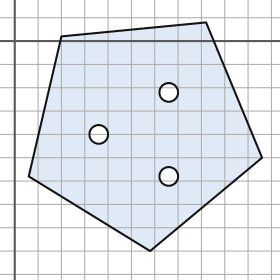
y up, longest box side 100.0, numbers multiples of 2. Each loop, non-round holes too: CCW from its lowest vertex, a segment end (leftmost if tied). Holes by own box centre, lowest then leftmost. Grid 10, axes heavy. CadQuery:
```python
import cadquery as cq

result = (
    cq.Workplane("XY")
    .moveTo(58.0, -90.0)
    .lineTo(106.0, -50.0)
    .lineTo(82.0, 8.0)
    .lineTo(20.0, 2.0)
    .lineTo(6.0, -58.0)
    .close()
    .moveTo(66.0, -58.0)
    .circle(4.0)
    .moveTo(36.0, -40.0)
    .circle(4.0)
    .moveTo(66.0, -22.0)
    .circle(4.0)
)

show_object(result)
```